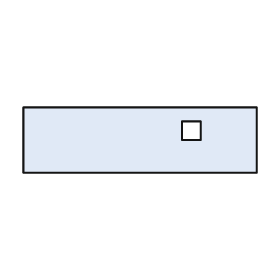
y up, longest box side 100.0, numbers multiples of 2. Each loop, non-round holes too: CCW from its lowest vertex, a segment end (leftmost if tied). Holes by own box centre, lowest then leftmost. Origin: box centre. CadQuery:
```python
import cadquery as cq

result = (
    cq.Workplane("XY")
    .moveTo(-50.0, -14.0)
    .lineTo(50.0, -14.0)
    .lineTo(50.0, 14.0)
    .lineTo(-50.0, 14.0)
    .close()
    .moveTo(18.0, 0.0)
    .lineTo(26.0, 0.0)
    .lineTo(26.0, 8.0)
    .lineTo(18.0, 8.0)
    .close()
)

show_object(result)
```